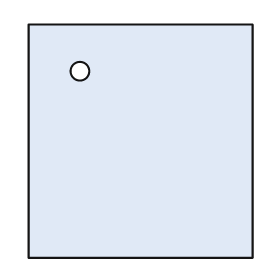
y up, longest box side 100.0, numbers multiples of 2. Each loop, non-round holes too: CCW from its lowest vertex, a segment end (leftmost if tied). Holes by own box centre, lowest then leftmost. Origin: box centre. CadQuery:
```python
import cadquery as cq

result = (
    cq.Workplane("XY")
    .moveTo(-48.0, -50.0)
    .lineTo(48.0, -50.0)
    .lineTo(48.0, 50.0)
    .lineTo(-48.0, 50.0)
    .close()
    .moveTo(-26.0, 30.0)
    .circle(4.0)
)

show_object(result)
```